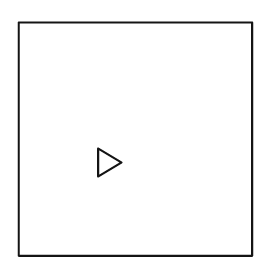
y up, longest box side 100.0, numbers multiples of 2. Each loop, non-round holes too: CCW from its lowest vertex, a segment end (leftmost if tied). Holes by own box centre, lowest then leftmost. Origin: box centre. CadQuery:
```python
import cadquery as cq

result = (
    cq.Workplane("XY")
    .moveTo(-50.0, -50.0)
    .lineTo(50.0, -50.0)
    .lineTo(50.0, 50.0)
    .lineTo(-50.0, 50.0)
    .close()
    .moveTo(-16.0, -16.0)
    .lineTo(-6.0, -10.0)
    .lineTo(-16.0, -4.0)
    .close()
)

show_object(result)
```